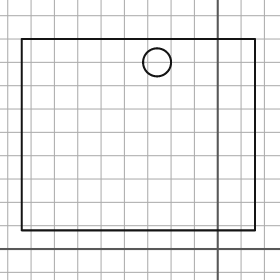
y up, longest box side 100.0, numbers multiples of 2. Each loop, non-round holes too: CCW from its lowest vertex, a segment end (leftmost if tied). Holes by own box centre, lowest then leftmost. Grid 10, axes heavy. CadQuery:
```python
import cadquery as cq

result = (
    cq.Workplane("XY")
    .moveTo(-84.0, 8.0)
    .lineTo(16.0, 8.0)
    .lineTo(16.0, 90.0)
    .lineTo(-84.0, 90.0)
    .close()
    .moveTo(-26.0, 80.0)
    .circle(6.0)
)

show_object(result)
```